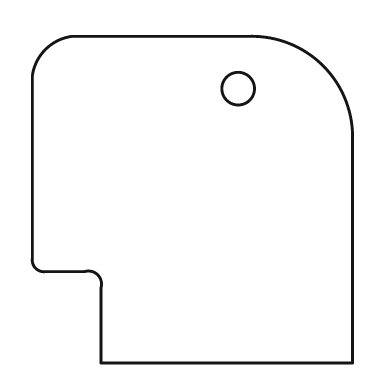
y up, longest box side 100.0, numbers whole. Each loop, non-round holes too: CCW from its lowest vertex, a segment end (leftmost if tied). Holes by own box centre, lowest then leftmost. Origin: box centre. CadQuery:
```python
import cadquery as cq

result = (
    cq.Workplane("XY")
    .moveTo(-28.0, -50.0)
    .lineTo(49.0, -50.0)
    .lineTo(49.0, 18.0)
    .threePointArc((40.0, 41.0), (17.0, 50.0))
    .lineTo(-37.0, 50.0)
    .threePointArc((-45.0, 46.0), (-49.0, 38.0))
    .lineTo(-49.0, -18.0)
    .threePointArc((-48.0, -21.0), (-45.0, -22.0))
    .lineTo(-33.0, -22.0)
    .threePointArc((-29.0, -23.0), (-28.0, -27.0))
    .close()
    .moveTo(14.0, 34.0)
    .circle(5.0)
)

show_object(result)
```